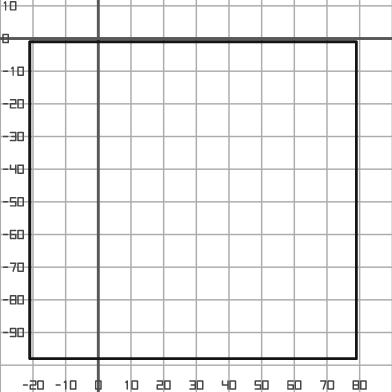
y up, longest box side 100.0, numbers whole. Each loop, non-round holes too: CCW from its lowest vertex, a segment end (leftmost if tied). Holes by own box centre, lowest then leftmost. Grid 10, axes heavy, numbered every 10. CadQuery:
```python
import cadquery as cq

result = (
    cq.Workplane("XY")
    .moveTo(-21.0, -98.0)
    .lineTo(79.0, -98.0)
    .lineTo(79.0, -1.0)
    .lineTo(-21.0, -1.0)
    .close()
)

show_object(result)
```